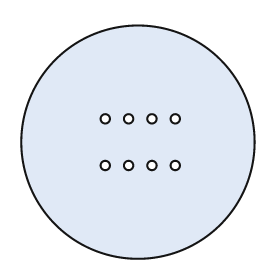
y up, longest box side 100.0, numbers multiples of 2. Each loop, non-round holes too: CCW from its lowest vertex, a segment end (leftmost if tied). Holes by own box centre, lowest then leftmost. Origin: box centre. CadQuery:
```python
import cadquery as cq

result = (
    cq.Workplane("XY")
    .moveTo(0.0, 0.0)
    .circle(50.0)
    .moveTo(-14.0, -10.0)
    .circle(2.0)
    .moveTo(-4.0, -10.0)
    .circle(2.0)
    .moveTo(6.0, -10.0)
    .circle(2.0)
    .moveTo(16.0, -10.0)
    .circle(2.0)
    .moveTo(-14.0, 10.0)
    .circle(2.0)
    .moveTo(-4.0, 10.0)
    .circle(2.0)
    .moveTo(6.0, 10.0)
    .circle(2.0)
    .moveTo(16.0, 10.0)
    .circle(2.0)
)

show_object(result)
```